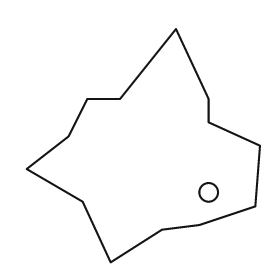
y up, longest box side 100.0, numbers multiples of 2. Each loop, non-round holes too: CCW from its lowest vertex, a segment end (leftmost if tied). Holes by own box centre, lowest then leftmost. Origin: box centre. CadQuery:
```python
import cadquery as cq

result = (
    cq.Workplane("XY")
    .moveTo(-14.0, -50.0)
    .lineTo(8.0, -36.0)
    .lineTo(24.0, -34.0)
    .lineTo(48.0, -26.0)
    .lineTo(50.0, 0.0)
    .lineTo(28.0, 10.0)
    .lineTo(28.0, 20.0)
    .lineTo(14.0, 50.0)
    .lineTo(-10.0, 20.0)
    .lineTo(-24.0, 20.0)
    .lineTo(-32.0, 4.0)
    .lineTo(-50.0, -10.0)
    .lineTo(-26.0, -24.0)
    .close()
    .moveTo(28.0, -20.0)
    .circle(4.0)
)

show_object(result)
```